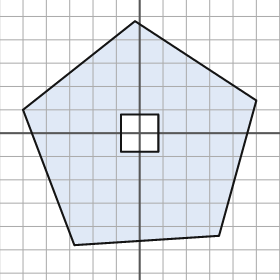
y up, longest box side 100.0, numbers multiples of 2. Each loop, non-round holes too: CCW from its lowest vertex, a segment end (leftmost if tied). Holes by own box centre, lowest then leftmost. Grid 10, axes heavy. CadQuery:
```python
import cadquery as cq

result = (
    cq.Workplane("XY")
    .moveTo(-28.0, -48.0)
    .lineTo(34.0, -44.0)
    .lineTo(50.0, 14.0)
    .lineTo(-2.0, 48.0)
    .lineTo(-50.0, 10.0)
    .close()
    .moveTo(-8.0, -8.0)
    .lineTo(8.0, -8.0)
    .lineTo(8.0, 8.0)
    .lineTo(-8.0, 8.0)
    .close()
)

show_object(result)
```